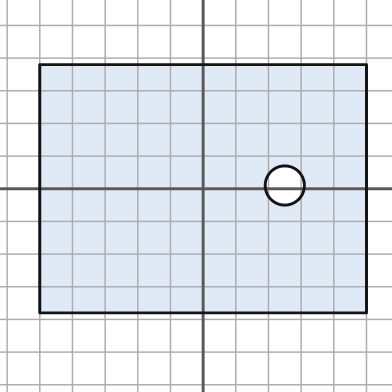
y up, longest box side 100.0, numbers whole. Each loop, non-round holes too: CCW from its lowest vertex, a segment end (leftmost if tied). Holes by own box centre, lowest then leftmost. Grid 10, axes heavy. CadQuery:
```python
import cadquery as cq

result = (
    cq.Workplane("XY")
    .moveTo(-50.0, -38.0)
    .lineTo(50.0, -38.0)
    .lineTo(50.0, 38.0)
    .lineTo(-50.0, 38.0)
    .close()
    .moveTo(25.0, 1.0)
    .circle(6.0)
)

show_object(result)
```